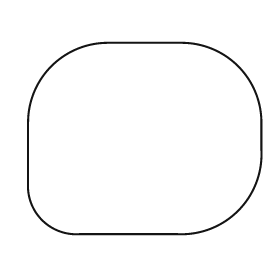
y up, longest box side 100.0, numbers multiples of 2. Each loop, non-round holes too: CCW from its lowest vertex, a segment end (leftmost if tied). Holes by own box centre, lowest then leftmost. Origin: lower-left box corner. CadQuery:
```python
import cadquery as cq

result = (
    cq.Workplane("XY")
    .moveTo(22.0, 0.0)
    .lineTo(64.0, 0.0)
    .threePointArc((90.0, 10.0), (100.0, 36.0))
    .lineTo(100.0, 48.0)
    .threePointArc((90.0, 72.0), (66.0, 82.0))
    .lineTo(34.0, 82.0)
    .threePointArc((10.0, 72.0), (0.0, 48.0))
    .lineTo(0.0, 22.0)
    .threePointArc((6.0, 6.0), (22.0, 0.0))
    .close()
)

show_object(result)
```